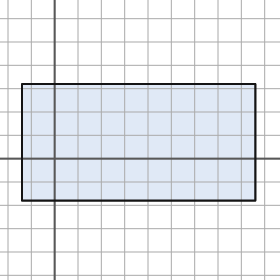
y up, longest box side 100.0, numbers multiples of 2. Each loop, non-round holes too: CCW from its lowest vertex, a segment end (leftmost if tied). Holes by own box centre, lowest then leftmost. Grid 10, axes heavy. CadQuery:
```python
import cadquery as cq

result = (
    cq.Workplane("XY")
    .moveTo(-14.0, -18.0)
    .lineTo(86.0, -18.0)
    .lineTo(86.0, 32.0)
    .lineTo(-14.0, 32.0)
    .close()
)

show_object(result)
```